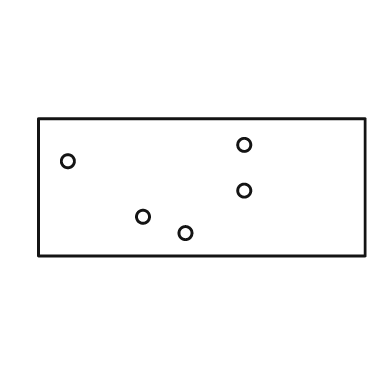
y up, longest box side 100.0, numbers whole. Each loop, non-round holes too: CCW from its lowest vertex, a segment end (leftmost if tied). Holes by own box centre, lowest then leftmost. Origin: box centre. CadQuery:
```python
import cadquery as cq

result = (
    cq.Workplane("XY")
    .moveTo(-50.0, -21.0)
    .lineTo(50.0, -21.0)
    .lineTo(50.0, 21.0)
    .lineTo(-50.0, 21.0)
    .close()
    .moveTo(-5.0, -14.0)
    .circle(2.0)
    .moveTo(-18.0, -9.0)
    .circle(2.0)
    .moveTo(13.0, -1.0)
    .circle(2.0)
    .moveTo(-41.0, 8.0)
    .circle(2.0)
    .moveTo(13.0, 13.0)
    .circle(2.0)
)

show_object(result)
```